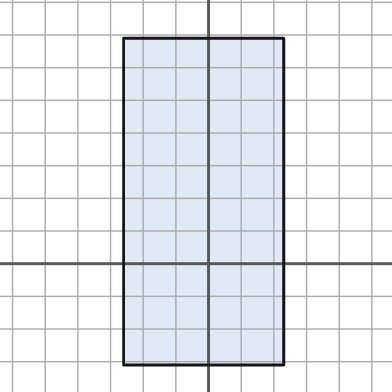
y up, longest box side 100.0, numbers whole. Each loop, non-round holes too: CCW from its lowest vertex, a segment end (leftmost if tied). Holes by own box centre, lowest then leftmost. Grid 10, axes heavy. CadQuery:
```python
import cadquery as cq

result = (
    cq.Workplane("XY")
    .moveTo(-26.0, -31.0)
    .lineTo(23.0, -31.0)
    .lineTo(23.0, 69.0)
    .lineTo(-26.0, 69.0)
    .close()
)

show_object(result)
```